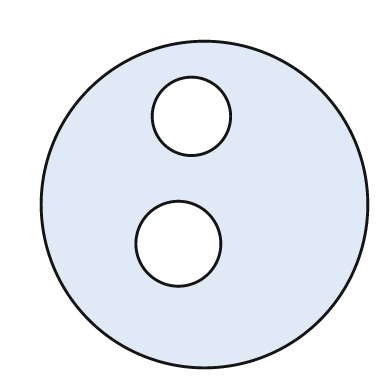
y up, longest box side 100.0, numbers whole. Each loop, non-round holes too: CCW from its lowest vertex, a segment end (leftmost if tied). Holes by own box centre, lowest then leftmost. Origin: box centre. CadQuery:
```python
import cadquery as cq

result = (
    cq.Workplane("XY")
    .moveTo(0.0, 0.0)
    .circle(50.0)
    .moveTo(-8.0, -12.0)
    .circle(13.0)
    .moveTo(-4.0, 27.0)
    .circle(12.0)
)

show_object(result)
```